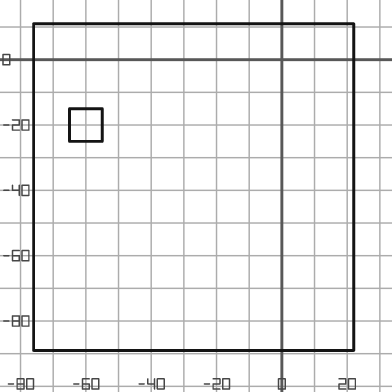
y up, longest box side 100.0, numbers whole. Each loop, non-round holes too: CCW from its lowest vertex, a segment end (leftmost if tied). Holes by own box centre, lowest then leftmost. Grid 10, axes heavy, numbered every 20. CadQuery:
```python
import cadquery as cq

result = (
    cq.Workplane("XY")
    .moveTo(-76.0, -89.0)
    .lineTo(22.0, -89.0)
    .lineTo(22.0, 11.0)
    .lineTo(-76.0, 11.0)
    .close()
    .moveTo(-65.0, -25.0)
    .lineTo(-55.0, -25.0)
    .lineTo(-55.0, -15.0)
    .lineTo(-65.0, -15.0)
    .close()
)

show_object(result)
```